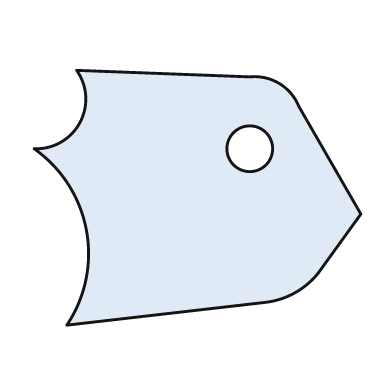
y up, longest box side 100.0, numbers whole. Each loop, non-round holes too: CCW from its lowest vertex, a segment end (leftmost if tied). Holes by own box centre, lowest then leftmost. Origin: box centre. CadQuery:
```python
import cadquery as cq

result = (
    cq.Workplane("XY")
    .moveTo(-40.0, -39.0)
    .lineTo(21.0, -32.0)
    .threePointArc((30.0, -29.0), (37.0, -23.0))
    .lineTo(50.0, -5.0)
    .lineTo(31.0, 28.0)
    .threePointArc((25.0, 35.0), (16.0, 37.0))
    .lineTo(-37.0, 39.0)
    .threePointArc((-36.0, 23.0), (-50.0, 15.0))
    .threePointArc((-34.0, -10.0), (-40.0, -39.0))
    .close()
    .moveTo(16.0, 15.0)
    .circle(7.0)
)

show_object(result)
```